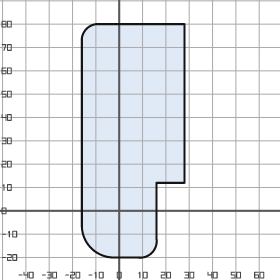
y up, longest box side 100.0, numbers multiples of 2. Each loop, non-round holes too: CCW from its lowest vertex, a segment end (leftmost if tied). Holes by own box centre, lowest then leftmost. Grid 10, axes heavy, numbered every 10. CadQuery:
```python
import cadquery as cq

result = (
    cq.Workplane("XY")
    .moveTo(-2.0, -20.0)
    .lineTo(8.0, -20.0)
    .threePointArc((14.0, -18.0), (16.0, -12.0))
    .lineTo(16.0, 12.0)
    .lineTo(28.0, 12.0)
    .lineTo(28.0, 80.0)
    .lineTo(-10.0, 80.0)
    .threePointArc((-14.0, 78.0), (-16.0, 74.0))
    .lineTo(-16.0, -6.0)
    .threePointArc((-12.0, -16.0), (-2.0, -20.0))
    .close()
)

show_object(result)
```